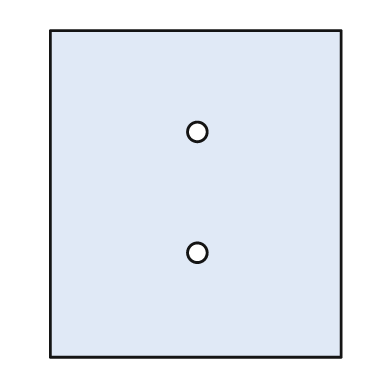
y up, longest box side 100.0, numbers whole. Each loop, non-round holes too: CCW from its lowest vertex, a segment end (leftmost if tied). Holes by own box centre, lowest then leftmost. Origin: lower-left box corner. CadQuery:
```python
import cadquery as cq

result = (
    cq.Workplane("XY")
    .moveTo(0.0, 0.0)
    .lineTo(89.0, 0.0)
    .lineTo(89.0, 100.0)
    .lineTo(0.0, 100.0)
    .close()
    .moveTo(45.0, 32.0)
    .circle(3.0)
    .moveTo(45.0, 69.0)
    .circle(3.0)
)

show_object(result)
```